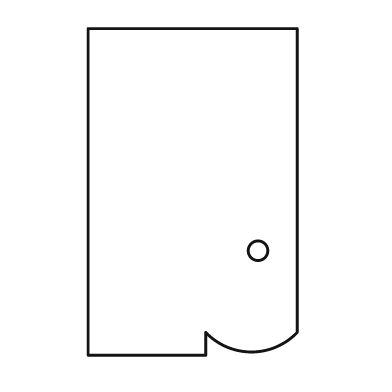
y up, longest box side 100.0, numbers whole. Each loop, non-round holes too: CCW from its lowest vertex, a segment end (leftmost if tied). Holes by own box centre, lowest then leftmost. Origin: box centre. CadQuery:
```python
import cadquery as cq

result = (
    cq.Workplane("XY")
    .moveTo(-32.0, -50.0)
    .lineTo(4.0, -50.0)
    .lineTo(4.0, -43.0)
    .threePointArc((18.0, -49.0), (32.0, -43.0))
    .lineTo(32.0, 50.0)
    .lineTo(-32.0, 50.0)
    .close()
    .moveTo(20.0, -18.0)
    .circle(3.0)
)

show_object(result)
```